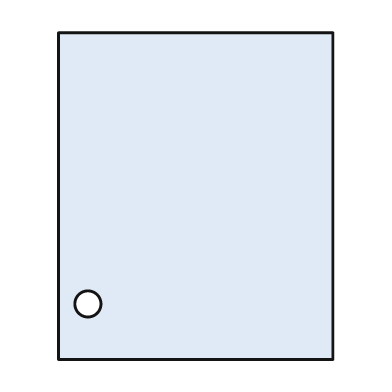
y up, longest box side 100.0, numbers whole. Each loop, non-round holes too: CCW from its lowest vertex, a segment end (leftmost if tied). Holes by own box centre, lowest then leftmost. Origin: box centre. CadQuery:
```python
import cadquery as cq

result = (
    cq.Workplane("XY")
    .moveTo(-42.0, -50.0)
    .lineTo(42.0, -50.0)
    .lineTo(42.0, 50.0)
    .lineTo(-42.0, 50.0)
    .close()
    .moveTo(-33.0, -33.0)
    .circle(4.0)
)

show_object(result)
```